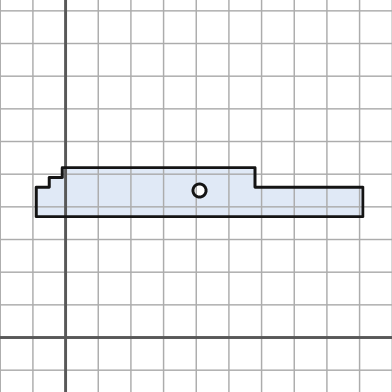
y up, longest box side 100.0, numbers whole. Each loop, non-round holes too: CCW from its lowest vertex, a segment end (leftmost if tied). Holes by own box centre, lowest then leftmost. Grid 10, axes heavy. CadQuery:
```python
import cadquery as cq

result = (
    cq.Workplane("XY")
    .moveTo(-9.0, 37.0)
    .lineTo(91.0, 37.0)
    .lineTo(91.0, 46.0)
    .lineTo(58.0, 46.0)
    .lineTo(58.0, 52.0)
    .lineTo(-1.0, 52.0)
    .lineTo(-1.0, 49.0)
    .lineTo(-5.0, 49.0)
    .lineTo(-5.0, 46.0)
    .lineTo(-9.0, 46.0)
    .close()
    .moveTo(41.0, 45.0)
    .circle(2.0)
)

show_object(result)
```